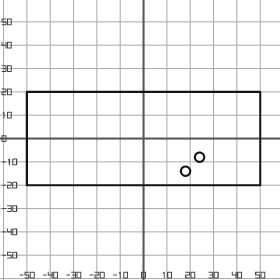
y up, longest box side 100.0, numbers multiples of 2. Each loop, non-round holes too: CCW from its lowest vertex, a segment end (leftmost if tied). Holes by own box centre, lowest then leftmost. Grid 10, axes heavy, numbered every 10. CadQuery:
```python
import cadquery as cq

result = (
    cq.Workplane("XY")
    .moveTo(-50.0, -20.0)
    .lineTo(50.0, -20.0)
    .lineTo(50.0, 20.0)
    .lineTo(-50.0, 20.0)
    .close()
    .moveTo(18.0, -14.0)
    .circle(2.0)
    .moveTo(24.0, -8.0)
    .circle(2.0)
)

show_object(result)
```